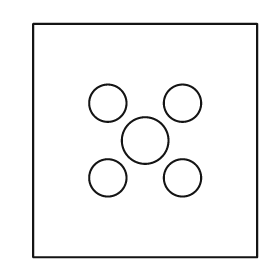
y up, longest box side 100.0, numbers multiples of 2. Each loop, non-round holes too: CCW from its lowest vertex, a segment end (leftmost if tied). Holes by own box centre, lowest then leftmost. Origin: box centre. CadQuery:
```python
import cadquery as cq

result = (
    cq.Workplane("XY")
    .moveTo(-48.0, -50.0)
    .lineTo(48.0, -50.0)
    .lineTo(48.0, 50.0)
    .lineTo(-48.0, 50.0)
    .close()
    .moveTo(-16.0, -16.0)
    .circle(8.0)
    .moveTo(16.0, -16.0)
    .circle(8.0)
    .moveTo(0.0, 0.0)
    .circle(10.0)
    .moveTo(-16.0, 16.0)
    .circle(8.0)
    .moveTo(16.0, 16.0)
    .circle(8.0)
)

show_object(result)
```